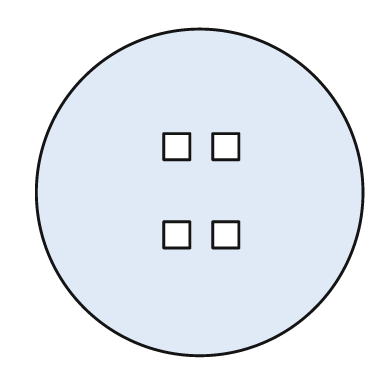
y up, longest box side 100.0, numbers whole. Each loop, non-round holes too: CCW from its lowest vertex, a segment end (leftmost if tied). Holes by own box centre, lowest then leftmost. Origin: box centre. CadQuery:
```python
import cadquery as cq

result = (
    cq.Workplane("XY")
    .moveTo(0.0, 0.0)
    .circle(50.0)
    .moveTo(-11.0, -17.0)
    .lineTo(-3.0, -17.0)
    .lineTo(-3.0, -9.0)
    .lineTo(-11.0, -9.0)
    .close()
    .moveTo(4.0, -17.0)
    .lineTo(12.0, -17.0)
    .lineTo(12.0, -9.0)
    .lineTo(4.0, -9.0)
    .close()
    .moveTo(-11.0, 10.0)
    .lineTo(-3.0, 10.0)
    .lineTo(-3.0, 18.0)
    .lineTo(-11.0, 18.0)
    .close()
    .moveTo(4.0, 10.0)
    .lineTo(12.0, 10.0)
    .lineTo(12.0, 18.0)
    .lineTo(4.0, 18.0)
    .close()
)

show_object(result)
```